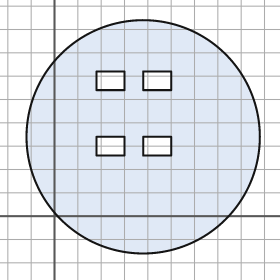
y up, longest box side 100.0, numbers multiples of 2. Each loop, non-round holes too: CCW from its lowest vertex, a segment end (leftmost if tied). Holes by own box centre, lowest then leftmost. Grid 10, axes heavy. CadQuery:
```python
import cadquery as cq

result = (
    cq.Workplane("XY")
    .moveTo(38.0, 34.0)
    .circle(50.0)
    .moveTo(18.0, 26.0)
    .lineTo(30.0, 26.0)
    .lineTo(30.0, 34.0)
    .lineTo(18.0, 34.0)
    .close()
    .moveTo(38.0, 26.0)
    .lineTo(50.0, 26.0)
    .lineTo(50.0, 34.0)
    .lineTo(38.0, 34.0)
    .close()
    .moveTo(18.0, 54.0)
    .lineTo(30.0, 54.0)
    .lineTo(30.0, 62.0)
    .lineTo(18.0, 62.0)
    .close()
    .moveTo(38.0, 54.0)
    .lineTo(50.0, 54.0)
    .lineTo(50.0, 62.0)
    .lineTo(38.0, 62.0)
    .close()
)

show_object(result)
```